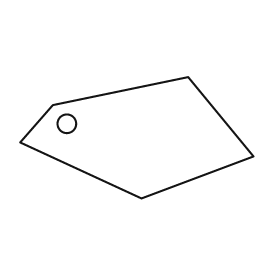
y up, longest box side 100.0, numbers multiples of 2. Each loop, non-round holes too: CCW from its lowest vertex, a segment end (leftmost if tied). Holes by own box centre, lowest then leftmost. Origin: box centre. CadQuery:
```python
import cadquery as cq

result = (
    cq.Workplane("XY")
    .moveTo(2.0, -26.0)
    .lineTo(50.0, -8.0)
    .lineTo(22.0, 26.0)
    .lineTo(-36.0, 14.0)
    .lineTo(-50.0, -2.0)
    .close()
    .moveTo(-30.0, 6.0)
    .circle(4.0)
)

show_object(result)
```